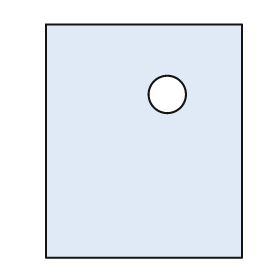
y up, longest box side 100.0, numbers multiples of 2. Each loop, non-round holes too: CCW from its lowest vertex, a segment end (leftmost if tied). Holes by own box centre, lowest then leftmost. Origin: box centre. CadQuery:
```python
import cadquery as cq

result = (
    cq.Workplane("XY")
    .moveTo(-42.0, -50.0)
    .lineTo(42.0, -50.0)
    .lineTo(42.0, 50.0)
    .lineTo(-42.0, 50.0)
    .close()
    .moveTo(10.0, 20.0)
    .circle(8.0)
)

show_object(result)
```